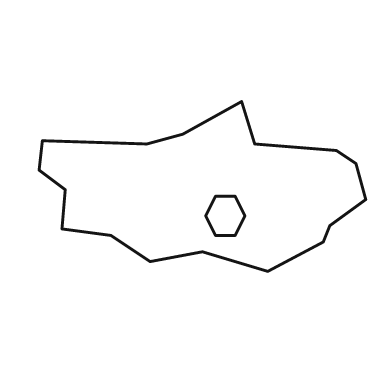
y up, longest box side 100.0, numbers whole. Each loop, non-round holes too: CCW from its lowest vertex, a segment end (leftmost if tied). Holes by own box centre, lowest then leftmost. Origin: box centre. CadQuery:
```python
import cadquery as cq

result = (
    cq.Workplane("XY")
    .moveTo(20.0, -26.0)
    .lineTo(37.0, -17.0)
    .lineTo(39.0, -12.0)
    .lineTo(50.0, -4.0)
    .lineTo(47.0, 7.0)
    .lineTo(41.0, 11.0)
    .lineTo(16.0, 13.0)
    .lineTo(12.0, 26.0)
    .lineTo(-6.0, 16.0)
    .lineTo(-17.0, 13.0)
    .lineTo(-49.0, 14.0)
    .lineTo(-50.0, 5.0)
    .lineTo(-42.0, -1.0)
    .lineTo(-43.0, -13.0)
    .lineTo(-28.0, -15.0)
    .lineTo(-16.0, -23.0)
    .lineTo(0.0, -20.0)
    .close()
    .moveTo(4.0, -15.0)
    .lineTo(10.0, -15.0)
    .lineTo(13.0, -9.0)
    .lineTo(10.0, -3.0)
    .lineTo(4.0, -3.0)
    .lineTo(1.0, -9.0)
    .close()
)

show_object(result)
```